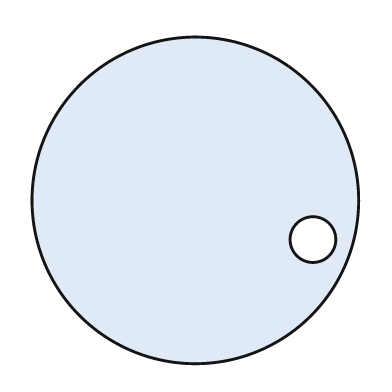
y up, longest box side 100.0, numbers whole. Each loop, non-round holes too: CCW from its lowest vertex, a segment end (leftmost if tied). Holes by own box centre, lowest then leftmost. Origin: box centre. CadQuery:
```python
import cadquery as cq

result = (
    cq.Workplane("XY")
    .moveTo(0.0, 0.0)
    .circle(50.0)
    .moveTo(36.0, -12.0)
    .circle(7.0)
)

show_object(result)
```